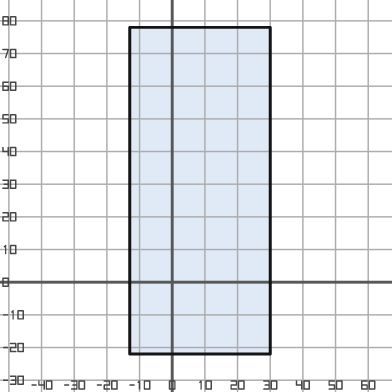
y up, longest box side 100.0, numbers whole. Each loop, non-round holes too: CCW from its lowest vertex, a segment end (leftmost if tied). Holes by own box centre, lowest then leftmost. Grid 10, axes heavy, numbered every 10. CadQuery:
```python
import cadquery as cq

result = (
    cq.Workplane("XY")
    .moveTo(-13.0, -22.0)
    .lineTo(30.0, -22.0)
    .lineTo(30.0, 78.0)
    .lineTo(-13.0, 78.0)
    .close()
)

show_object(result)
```